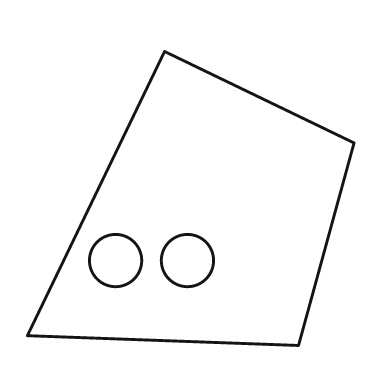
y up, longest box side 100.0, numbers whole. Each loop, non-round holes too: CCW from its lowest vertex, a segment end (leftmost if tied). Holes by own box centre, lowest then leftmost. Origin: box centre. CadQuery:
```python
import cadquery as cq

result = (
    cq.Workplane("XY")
    .moveTo(33.0, -45.0)
    .lineTo(50.0, 17.0)
    .lineTo(-8.0, 45.0)
    .lineTo(-50.0, -42.0)
    .close()
    .moveTo(-23.0, -19.0)
    .circle(8.0)
    .moveTo(-1.0, -19.0)
    .circle(8.0)
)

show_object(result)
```